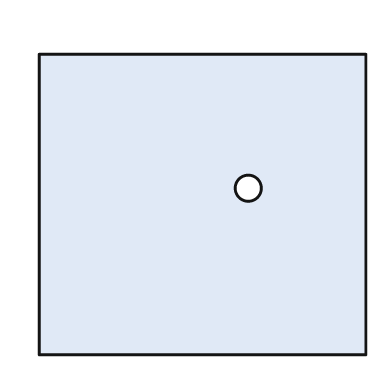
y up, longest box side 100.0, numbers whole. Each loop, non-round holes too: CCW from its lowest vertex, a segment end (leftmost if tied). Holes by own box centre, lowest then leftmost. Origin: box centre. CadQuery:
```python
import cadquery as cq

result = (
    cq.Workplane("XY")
    .moveTo(-50.0, -46.0)
    .lineTo(50.0, -46.0)
    .lineTo(50.0, 46.0)
    .lineTo(-50.0, 46.0)
    .close()
    .moveTo(14.0, 5.0)
    .circle(4.0)
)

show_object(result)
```